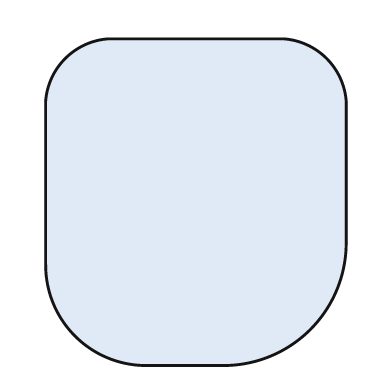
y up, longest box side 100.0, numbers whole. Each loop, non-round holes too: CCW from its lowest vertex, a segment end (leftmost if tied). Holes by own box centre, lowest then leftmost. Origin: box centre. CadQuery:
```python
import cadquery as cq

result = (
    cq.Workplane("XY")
    .moveTo(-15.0, -50.0)
    .lineTo(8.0, -50.0)
    .threePointArc((35.0, -39.0), (46.0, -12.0))
    .lineTo(46.0, 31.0)
    .threePointArc((40.0, 44.0), (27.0, 50.0))
    .lineTo(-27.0, 50.0)
    .threePointArc((-40.0, 44.0), (-46.0, 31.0))
    .lineTo(-46.0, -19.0)
    .threePointArc((-37.0, -41.0), (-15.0, -50.0))
    .close()
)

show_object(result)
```